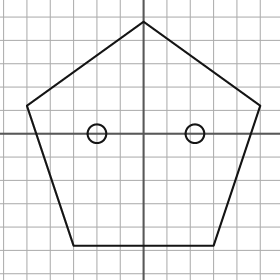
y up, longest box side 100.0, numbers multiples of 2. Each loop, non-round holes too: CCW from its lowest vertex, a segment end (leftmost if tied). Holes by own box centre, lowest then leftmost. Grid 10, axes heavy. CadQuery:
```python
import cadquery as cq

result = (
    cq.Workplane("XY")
    .moveTo(-30.0, -48.0)
    .lineTo(30.0, -48.0)
    .lineTo(50.0, 12.0)
    .lineTo(0.0, 48.0)
    .lineTo(-50.0, 12.0)
    .close()
    .moveTo(-20.0, 0.0)
    .circle(4.0)
    .moveTo(22.0, 0.0)
    .circle(4.0)
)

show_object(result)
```